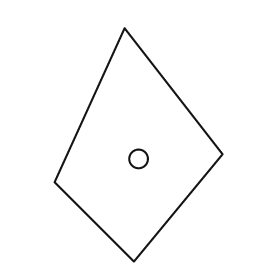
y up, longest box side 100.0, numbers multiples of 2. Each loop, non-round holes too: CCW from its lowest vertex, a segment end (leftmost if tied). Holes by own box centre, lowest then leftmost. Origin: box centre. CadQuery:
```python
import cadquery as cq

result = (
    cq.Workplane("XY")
    .moveTo(-2.0, -50.0)
    .lineTo(36.0, -4.0)
    .lineTo(-6.0, 50.0)
    .lineTo(-36.0, -16.0)
    .close()
    .moveTo(0.0, -6.0)
    .circle(4.0)
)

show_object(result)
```